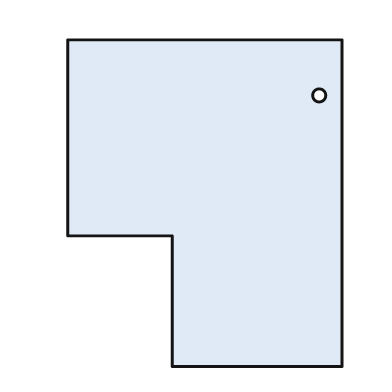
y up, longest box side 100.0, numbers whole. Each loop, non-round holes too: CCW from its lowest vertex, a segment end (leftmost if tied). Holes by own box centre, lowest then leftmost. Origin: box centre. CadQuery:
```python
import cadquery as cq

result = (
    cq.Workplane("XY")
    .moveTo(-10.0, -50.0)
    .lineTo(42.0, -50.0)
    .lineTo(42.0, 50.0)
    .lineTo(-42.0, 50.0)
    .lineTo(-42.0, -10.0)
    .lineTo(-10.0, -10.0)
    .close()
    .moveTo(35.0, 33.0)
    .circle(2.0)
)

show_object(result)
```